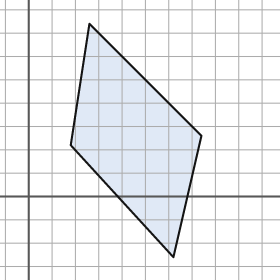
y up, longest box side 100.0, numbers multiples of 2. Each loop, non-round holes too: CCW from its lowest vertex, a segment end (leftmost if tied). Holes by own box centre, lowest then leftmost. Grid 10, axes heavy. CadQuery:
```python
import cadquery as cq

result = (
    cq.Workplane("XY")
    .moveTo(62.0, -26.0)
    .lineTo(74.0, 26.0)
    .lineTo(26.0, 74.0)
    .lineTo(18.0, 22.0)
    .close()
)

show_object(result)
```